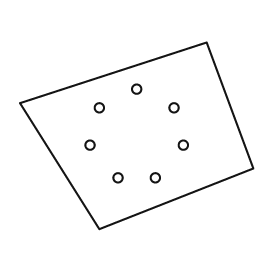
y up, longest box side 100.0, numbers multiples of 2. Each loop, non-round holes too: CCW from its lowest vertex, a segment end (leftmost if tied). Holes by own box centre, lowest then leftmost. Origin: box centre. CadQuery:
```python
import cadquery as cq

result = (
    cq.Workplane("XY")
    .moveTo(-16.0, -40.0)
    .lineTo(50.0, -14.0)
    .lineTo(30.0, 40.0)
    .lineTo(-50.0, 14.0)
    .close()
    .moveTo(-8.0, -18.0)
    .circle(2.0)
    .moveTo(8.0, -18.0)
    .circle(2.0)
    .moveTo(-20.0, -4.0)
    .circle(2.0)
    .moveTo(20.0, -4.0)
    .circle(2.0)
    .moveTo(-16.0, 12.0)
    .circle(2.0)
    .moveTo(16.0, 12.0)
    .circle(2.0)
    .moveTo(0.0, 20.0)
    .circle(2.0)
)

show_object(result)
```